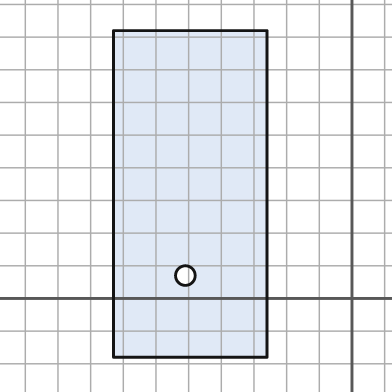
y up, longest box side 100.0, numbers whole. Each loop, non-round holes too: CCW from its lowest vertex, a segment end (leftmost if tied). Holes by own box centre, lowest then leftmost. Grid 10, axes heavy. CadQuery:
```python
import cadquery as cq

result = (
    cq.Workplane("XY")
    .moveTo(-73.0, -18.0)
    .lineTo(-26.0, -18.0)
    .lineTo(-26.0, 82.0)
    .lineTo(-73.0, 82.0)
    .close()
    .moveTo(-51.0, 7.0)
    .circle(3.0)
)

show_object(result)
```